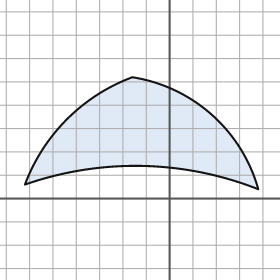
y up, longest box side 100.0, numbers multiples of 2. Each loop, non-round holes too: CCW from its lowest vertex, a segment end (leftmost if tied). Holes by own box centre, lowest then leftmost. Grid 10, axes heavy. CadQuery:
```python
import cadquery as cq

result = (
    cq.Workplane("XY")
    .moveTo(38.0, 4.0)
    .threePointArc((18.0, 36.0), (-16.0, 52.0))
    .threePointArc((-44.0, 34.0), (-62.0, 6.0))
    .threePointArc((-12.0, 14.0), (38.0, 4.0))
    .close()
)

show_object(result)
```